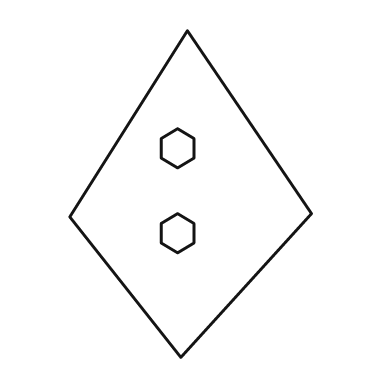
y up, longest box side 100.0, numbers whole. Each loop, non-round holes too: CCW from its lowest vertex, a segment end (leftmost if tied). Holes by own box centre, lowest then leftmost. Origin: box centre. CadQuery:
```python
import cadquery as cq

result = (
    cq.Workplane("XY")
    .moveTo(-3.0, -50.0)
    .lineTo(37.0, -6.0)
    .lineTo(-1.0, 50.0)
    .lineTo(-37.0, -7.0)
    .close()
    .moveTo(-4.0, -18.0)
    .lineTo(1.0, -15.0)
    .lineTo(1.0, -9.0)
    .lineTo(-4.0, -6.0)
    .lineTo(-9.0, -9.0)
    .lineTo(-9.0, -15.0)
    .close()
    .moveTo(-4.0, 8.0)
    .lineTo(1.0, 11.0)
    .lineTo(1.0, 17.0)
    .lineTo(-4.0, 20.0)
    .lineTo(-9.0, 17.0)
    .lineTo(-9.0, 11.0)
    .close()
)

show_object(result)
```